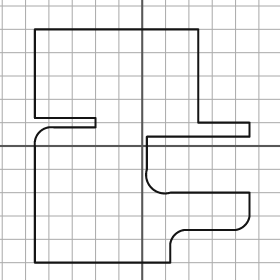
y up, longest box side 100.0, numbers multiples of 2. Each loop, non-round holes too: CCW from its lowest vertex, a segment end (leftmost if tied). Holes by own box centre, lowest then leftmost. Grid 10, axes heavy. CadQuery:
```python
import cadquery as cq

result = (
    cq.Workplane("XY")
    .moveTo(-46.0, -50.0)
    .lineTo(12.0, -50.0)
    .lineTo(12.0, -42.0)
    .threePointArc((14.0, -38.0), (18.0, -36.0))
    .lineTo(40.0, -36.0)
    .threePointArc((44.0, -34.0), (46.0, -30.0))
    .lineTo(46.0, -20.0)
    .lineTo(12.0, -20.0)
    .threePointArc((4.0, -18.0), (2.0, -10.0))
    .lineTo(2.0, 4.0)
    .lineTo(46.0, 4.0)
    .lineTo(46.0, 10.0)
    .lineTo(24.0, 10.0)
    .lineTo(24.0, 50.0)
    .lineTo(-46.0, 50.0)
    .lineTo(-46.0, 12.0)
    .lineTo(-20.0, 12.0)
    .lineTo(-20.0, 8.0)
    .lineTo(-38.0, 8.0)
    .threePointArc((-44.0, 6.0), (-46.0, 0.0))
    .close()
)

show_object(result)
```